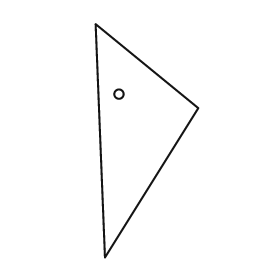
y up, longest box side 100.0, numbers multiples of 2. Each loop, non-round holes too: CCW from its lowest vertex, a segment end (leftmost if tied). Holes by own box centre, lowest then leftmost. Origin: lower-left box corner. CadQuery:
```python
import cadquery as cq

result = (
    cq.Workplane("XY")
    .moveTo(4.0, 0.0)
    .lineTo(44.0, 64.0)
    .lineTo(0.0, 100.0)
    .close()
    .moveTo(10.0, 70.0)
    .circle(2.0)
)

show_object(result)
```